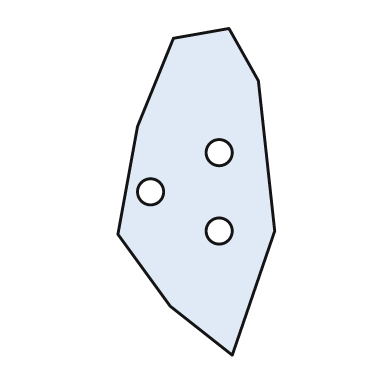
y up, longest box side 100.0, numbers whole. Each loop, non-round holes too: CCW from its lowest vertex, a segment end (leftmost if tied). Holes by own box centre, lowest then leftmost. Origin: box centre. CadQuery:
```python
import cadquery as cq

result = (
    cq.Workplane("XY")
    .moveTo(11.0, -50.0)
    .lineTo(24.0, -12.0)
    .lineTo(19.0, 34.0)
    .lineTo(10.0, 50.0)
    .lineTo(-7.0, 47.0)
    .lineTo(-18.0, 20.0)
    .lineTo(-24.0, -13.0)
    .lineTo(-8.0, -35.0)
    .close()
    .moveTo(7.0, -12.0)
    .circle(4.0)
    .moveTo(-14.0, 0.0)
    .circle(4.0)
    .moveTo(7.0, 12.0)
    .circle(4.0)
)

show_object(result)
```